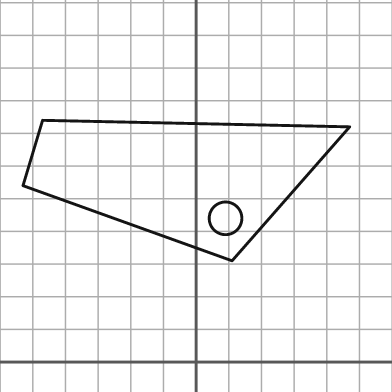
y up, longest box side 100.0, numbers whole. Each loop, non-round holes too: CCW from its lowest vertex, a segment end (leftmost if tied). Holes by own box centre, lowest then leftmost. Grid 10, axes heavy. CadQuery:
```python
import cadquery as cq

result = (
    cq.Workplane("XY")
    .moveTo(11.0, 31.0)
    .lineTo(47.0, 72.0)
    .lineTo(-47.0, 74.0)
    .lineTo(-53.0, 54.0)
    .close()
    .moveTo(9.0, 44.0)
    .circle(5.0)
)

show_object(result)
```